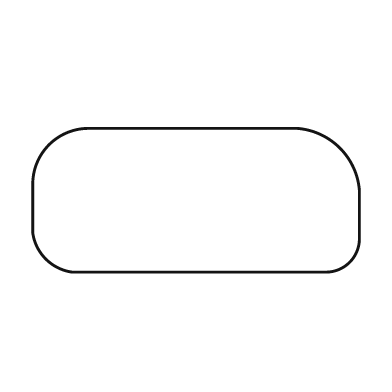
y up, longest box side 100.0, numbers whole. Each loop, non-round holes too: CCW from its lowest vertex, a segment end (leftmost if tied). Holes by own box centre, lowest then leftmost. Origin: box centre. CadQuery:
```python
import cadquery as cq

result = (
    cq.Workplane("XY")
    .moveTo(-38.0, -22.0)
    .lineTo(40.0, -22.0)
    .threePointArc((47.0, -19.0), (50.0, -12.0))
    .lineTo(50.0, 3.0)
    .threePointArc((44.0, 16.0), (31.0, 22.0))
    .lineTo(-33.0, 22.0)
    .threePointArc((-45.0, 17.0), (-50.0, 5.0))
    .lineTo(-50.0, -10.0)
    .threePointArc((-46.0, -18.0), (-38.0, -22.0))
    .close()
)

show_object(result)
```